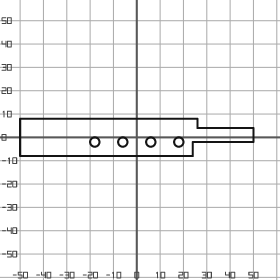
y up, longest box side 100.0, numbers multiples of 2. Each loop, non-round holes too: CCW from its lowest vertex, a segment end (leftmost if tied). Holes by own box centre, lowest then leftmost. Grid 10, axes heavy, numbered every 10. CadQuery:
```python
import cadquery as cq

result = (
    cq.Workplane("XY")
    .moveTo(-50.0, -8.0)
    .lineTo(24.0, -8.0)
    .lineTo(24.0, -2.0)
    .lineTo(50.0, -2.0)
    .lineTo(50.0, 4.0)
    .lineTo(26.0, 4.0)
    .lineTo(26.0, 8.0)
    .lineTo(-50.0, 8.0)
    .close()
    .moveTo(-18.0, -2.0)
    .circle(2.0)
    .moveTo(-6.0, -2.0)
    .circle(2.0)
    .moveTo(6.0, -2.0)
    .circle(2.0)
    .moveTo(18.0, -2.0)
    .circle(2.0)
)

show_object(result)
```